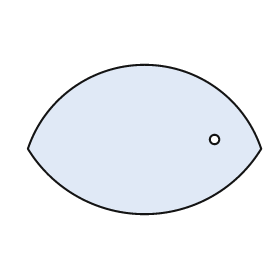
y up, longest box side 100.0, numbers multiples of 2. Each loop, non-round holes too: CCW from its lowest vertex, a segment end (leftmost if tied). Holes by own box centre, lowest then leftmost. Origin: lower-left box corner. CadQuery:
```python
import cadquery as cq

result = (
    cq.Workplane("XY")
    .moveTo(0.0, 28.0)
    .threePointArc((50.0, 0.0), (100.0, 28.0))
    .threePointArc((50.0, 64.0), (0.0, 28.0))
    .close()
    .moveTo(80.0, 32.0)
    .circle(2.0)
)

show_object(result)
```